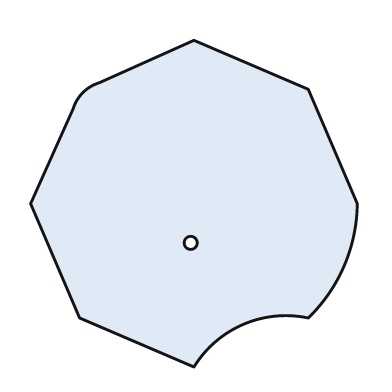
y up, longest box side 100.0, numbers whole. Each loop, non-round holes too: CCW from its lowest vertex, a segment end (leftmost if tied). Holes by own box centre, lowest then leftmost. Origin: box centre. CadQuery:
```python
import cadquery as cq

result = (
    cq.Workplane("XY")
    .moveTo(0.0, -50.0)
    .threePointArc((15.0, -37.0), (35.0, -35.0))
    .threePointArc((46.0, -19.0), (50.0, 0.0))
    .lineTo(35.0, 35.0)
    .lineTo(0.0, 50.0)
    .lineTo(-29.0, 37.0)
    .threePointArc((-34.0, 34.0), (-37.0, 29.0))
    .lineTo(-50.0, 0.0)
    .lineTo(-35.0, -35.0)
    .close()
    .moveTo(-1.0, -12.0)
    .circle(2.0)
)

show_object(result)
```